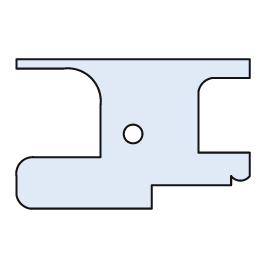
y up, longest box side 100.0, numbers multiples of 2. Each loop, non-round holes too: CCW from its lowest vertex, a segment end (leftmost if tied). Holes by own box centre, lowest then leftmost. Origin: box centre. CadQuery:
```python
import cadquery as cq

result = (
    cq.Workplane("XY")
    .moveTo(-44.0, -32.0)
    .lineTo(8.0, -32.0)
    .lineTo(8.0, -22.0)
    .lineTo(42.0, -22.0)
    .lineTo(42.0, -18.0)
    .threePointArc((46.0, -20.0), (50.0, -18.0))
    .lineTo(50.0, -8.0)
    .lineTo(28.0, -8.0)
    .lineTo(28.0, 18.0)
    .threePointArc((30.0, 22.0), (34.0, 24.0))
    .lineTo(50.0, 24.0)
    .lineTo(50.0, 32.0)
    .lineTo(-50.0, 32.0)
    .lineTo(-50.0, 28.0)
    .lineTo(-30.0, 28.0)
    .threePointArc((-18.0, 24.0), (-14.0, 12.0))
    .lineTo(-14.0, -10.0)
    .lineTo(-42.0, -10.0)
    .threePointArc((-48.0, -12.0), (-50.0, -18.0))
    .lineTo(-50.0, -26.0)
    .threePointArc((-48.0, -30.0), (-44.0, -32.0))
    .close()
    .moveTo(0.0, 0.0)
    .circle(4.0)
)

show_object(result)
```